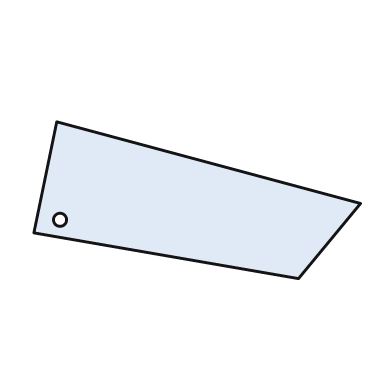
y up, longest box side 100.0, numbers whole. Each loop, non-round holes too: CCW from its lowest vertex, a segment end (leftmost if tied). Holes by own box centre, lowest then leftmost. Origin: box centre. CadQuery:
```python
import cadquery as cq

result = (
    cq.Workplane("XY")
    .moveTo(31.0, -24.0)
    .lineTo(50.0, -1.0)
    .lineTo(-43.0, 24.0)
    .lineTo(-50.0, -10.0)
    .close()
    .moveTo(-42.0, -6.0)
    .circle(2.0)
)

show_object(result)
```